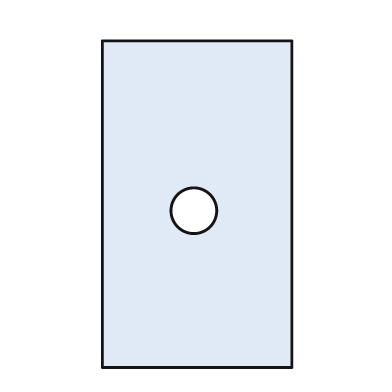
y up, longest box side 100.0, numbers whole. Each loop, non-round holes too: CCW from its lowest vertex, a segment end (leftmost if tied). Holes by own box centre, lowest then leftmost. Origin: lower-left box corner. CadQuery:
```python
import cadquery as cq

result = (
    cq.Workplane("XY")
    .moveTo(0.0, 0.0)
    .lineTo(58.0, 0.0)
    .lineTo(58.0, 100.0)
    .lineTo(0.0, 100.0)
    .close()
    .moveTo(28.0, 48.0)
    .circle(7.0)
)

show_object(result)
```